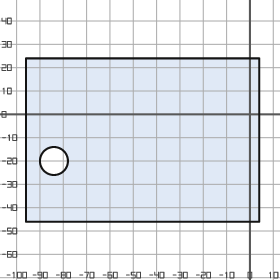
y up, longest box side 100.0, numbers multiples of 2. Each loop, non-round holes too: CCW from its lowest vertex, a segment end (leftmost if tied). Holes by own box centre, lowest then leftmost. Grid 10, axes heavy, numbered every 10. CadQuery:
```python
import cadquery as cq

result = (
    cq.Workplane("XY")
    .moveTo(-96.0, -46.0)
    .lineTo(4.0, -46.0)
    .lineTo(4.0, 24.0)
    .lineTo(-96.0, 24.0)
    .close()
    .moveTo(-84.0, -20.0)
    .circle(6.0)
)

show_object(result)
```